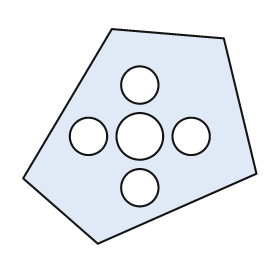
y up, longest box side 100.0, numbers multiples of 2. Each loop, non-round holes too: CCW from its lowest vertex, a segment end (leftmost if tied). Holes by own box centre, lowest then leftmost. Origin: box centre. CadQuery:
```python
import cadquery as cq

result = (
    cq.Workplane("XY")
    .moveTo(-18.0, -46.0)
    .lineTo(50.0, -16.0)
    .lineTo(36.0, 42.0)
    .lineTo(-12.0, 46.0)
    .lineTo(-50.0, -18.0)
    .close()
    .moveTo(0.0, -22.0)
    .circle(8.0)
    .moveTo(-22.0, 0.0)
    .circle(8.0)
    .moveTo(0.0, 0.0)
    .circle(10.0)
    .moveTo(22.0, 0.0)
    .circle(8.0)
    .moveTo(0.0, 22.0)
    .circle(8.0)
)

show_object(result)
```